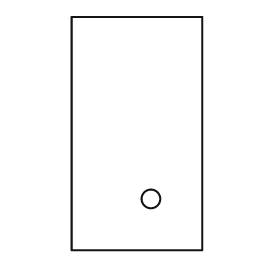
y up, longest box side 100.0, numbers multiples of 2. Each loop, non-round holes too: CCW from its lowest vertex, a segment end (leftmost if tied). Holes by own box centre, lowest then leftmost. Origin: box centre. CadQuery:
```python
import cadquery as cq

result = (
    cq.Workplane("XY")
    .moveTo(-28.0, -50.0)
    .lineTo(28.0, -50.0)
    .lineTo(28.0, 50.0)
    .lineTo(-28.0, 50.0)
    .close()
    .moveTo(6.0, -28.0)
    .circle(4.0)
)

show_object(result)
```